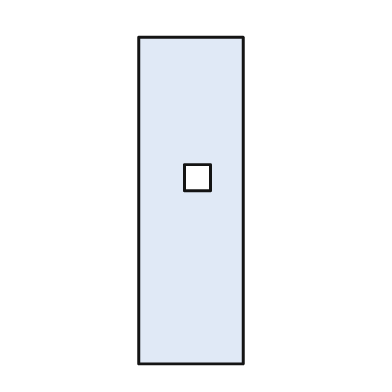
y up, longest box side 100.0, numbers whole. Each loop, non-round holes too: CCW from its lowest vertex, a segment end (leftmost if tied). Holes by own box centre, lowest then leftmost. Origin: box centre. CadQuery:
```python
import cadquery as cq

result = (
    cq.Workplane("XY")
    .moveTo(-16.0, -50.0)
    .lineTo(16.0, -50.0)
    .lineTo(16.0, 50.0)
    .lineTo(-16.0, 50.0)
    .close()
    .moveTo(-2.0, 3.0)
    .lineTo(6.0, 3.0)
    .lineTo(6.0, 11.0)
    .lineTo(-2.0, 11.0)
    .close()
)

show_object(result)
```